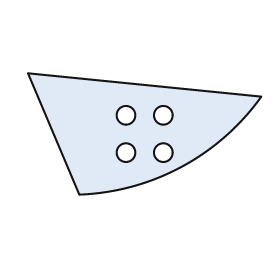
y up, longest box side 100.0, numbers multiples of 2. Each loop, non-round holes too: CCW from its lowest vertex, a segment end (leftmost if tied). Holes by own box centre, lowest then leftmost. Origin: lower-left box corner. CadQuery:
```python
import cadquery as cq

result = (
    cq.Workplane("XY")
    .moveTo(22.0, 0.0)
    .threePointArc((66.0, 12.0), (100.0, 42.0))
    .lineTo(0.0, 52.0)
    .close()
    .moveTo(42.0, 18.0)
    .circle(4.0)
    .moveTo(58.0, 18.0)
    .circle(4.0)
    .moveTo(42.0, 34.0)
    .circle(4.0)
    .moveTo(58.0, 34.0)
    .circle(4.0)
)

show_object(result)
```